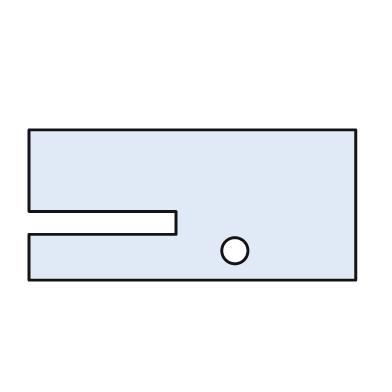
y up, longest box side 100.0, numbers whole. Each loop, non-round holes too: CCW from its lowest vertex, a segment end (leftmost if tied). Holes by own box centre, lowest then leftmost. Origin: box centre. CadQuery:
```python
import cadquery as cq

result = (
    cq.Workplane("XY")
    .moveTo(-50.0, -23.0)
    .lineTo(50.0, -23.0)
    .lineTo(50.0, 23.0)
    .lineTo(-50.0, 23.0)
    .lineTo(-50.0, -2.0)
    .lineTo(-5.0, -2.0)
    .lineTo(-5.0, -9.0)
    .lineTo(-50.0, -9.0)
    .close()
    .moveTo(13.0, -14.0)
    .circle(4.0)
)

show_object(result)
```